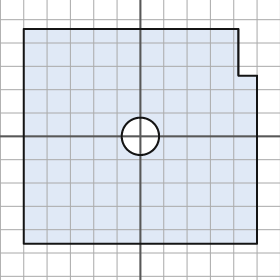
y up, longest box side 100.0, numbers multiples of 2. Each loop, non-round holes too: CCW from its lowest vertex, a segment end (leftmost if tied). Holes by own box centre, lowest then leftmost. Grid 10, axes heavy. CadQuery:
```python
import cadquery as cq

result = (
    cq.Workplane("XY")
    .moveTo(-50.0, -46.0)
    .lineTo(50.0, -46.0)
    .lineTo(50.0, 26.0)
    .lineTo(42.0, 26.0)
    .lineTo(42.0, 46.0)
    .lineTo(-50.0, 46.0)
    .close()
    .moveTo(0.0, 0.0)
    .circle(8.0)
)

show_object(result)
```